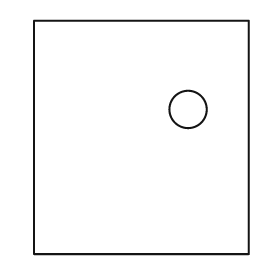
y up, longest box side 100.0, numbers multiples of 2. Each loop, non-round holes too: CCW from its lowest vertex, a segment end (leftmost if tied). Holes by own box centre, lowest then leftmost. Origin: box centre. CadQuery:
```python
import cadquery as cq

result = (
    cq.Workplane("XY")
    .moveTo(-46.0, -50.0)
    .lineTo(46.0, -50.0)
    .lineTo(46.0, 50.0)
    .lineTo(-46.0, 50.0)
    .close()
    .moveTo(20.0, 12.0)
    .circle(8.0)
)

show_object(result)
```